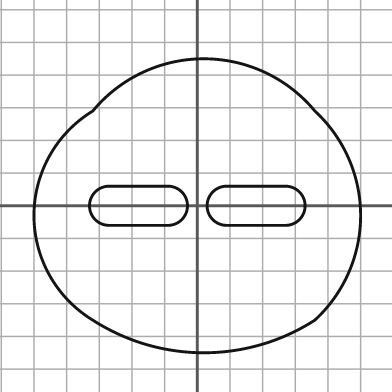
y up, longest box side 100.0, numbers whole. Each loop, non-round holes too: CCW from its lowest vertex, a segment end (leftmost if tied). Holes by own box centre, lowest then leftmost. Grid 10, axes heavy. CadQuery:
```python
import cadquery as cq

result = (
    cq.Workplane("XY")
    .moveTo(-32.0, -35.0)
    .threePointArc((2.0, -45.0), (36.0, -35.0))
    .threePointArc((50.0, -3.0), (36.0, 29.0))
    .threePointArc((2.0, 45.0), (-32.0, 29.0))
    .threePointArc((-50.0, -3.0), (-32.0, -35.0))
    .close()
    .moveTo(-27.0, -6.0)
    .lineTo(-9.0, -6.0)
    .threePointArc((-3.0, 0.0), (-9.0, 6.0))
    .lineTo(-27.0, 6.0)
    .threePointArc((-33.0, 0.0), (-27.0, -6.0))
    .close()
    .moveTo(9.0, -6.0)
    .lineTo(27.0, -6.0)
    .threePointArc((33.0, 0.0), (27.0, 6.0))
    .lineTo(9.0, 6.0)
    .threePointArc((3.0, 0.0), (9.0, -6.0))
    .close()
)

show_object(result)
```